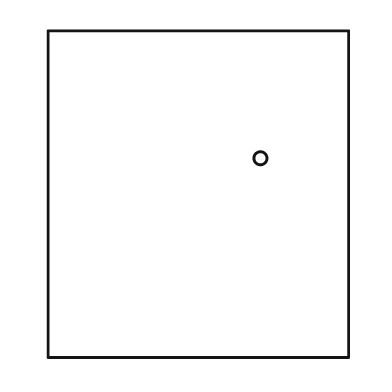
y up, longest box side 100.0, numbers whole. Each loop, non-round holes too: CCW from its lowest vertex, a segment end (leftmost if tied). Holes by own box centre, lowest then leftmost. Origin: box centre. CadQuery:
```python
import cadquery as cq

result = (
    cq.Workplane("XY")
    .moveTo(-46.0, -50.0)
    .lineTo(46.0, -50.0)
    .lineTo(46.0, 50.0)
    .lineTo(-46.0, 50.0)
    .close()
    .moveTo(19.0, 11.0)
    .circle(2.0)
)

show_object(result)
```